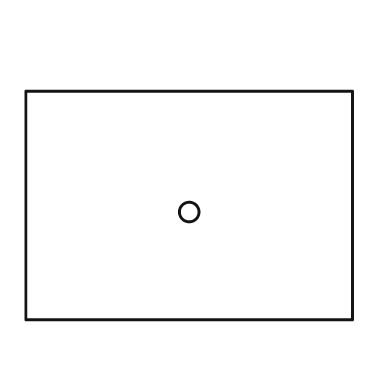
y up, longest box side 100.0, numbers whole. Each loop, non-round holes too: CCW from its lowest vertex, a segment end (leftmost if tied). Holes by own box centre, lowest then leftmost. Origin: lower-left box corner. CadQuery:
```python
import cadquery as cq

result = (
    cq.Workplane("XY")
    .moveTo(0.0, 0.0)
    .lineTo(100.0, 0.0)
    .lineTo(100.0, 70.0)
    .lineTo(0.0, 70.0)
    .close()
    .moveTo(50.0, 33.0)
    .circle(3.0)
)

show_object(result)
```